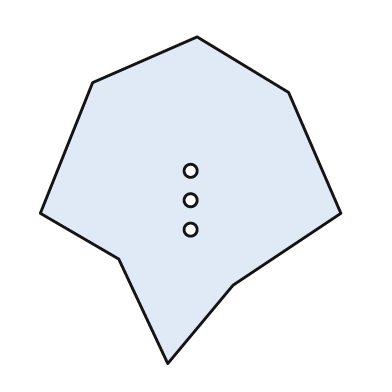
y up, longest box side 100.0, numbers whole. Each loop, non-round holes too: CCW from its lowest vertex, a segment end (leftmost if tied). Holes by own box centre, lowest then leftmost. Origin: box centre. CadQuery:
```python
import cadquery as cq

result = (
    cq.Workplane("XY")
    .moveTo(-7.0, -50.0)
    .lineTo(13.0, -26.0)
    .lineTo(46.0, -4.0)
    .lineTo(30.0, 33.0)
    .lineTo(2.0, 50.0)
    .lineTo(-30.0, 36.0)
    .lineTo(-46.0, -4.0)
    .lineTo(-22.0, -18.0)
    .close()
    .moveTo(0.0, -9.0)
    .circle(2.0)
    .moveTo(0.0, 0.0)
    .circle(2.0)
    .moveTo(0.0, 9.0)
    .circle(2.0)
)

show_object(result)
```